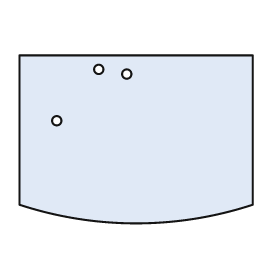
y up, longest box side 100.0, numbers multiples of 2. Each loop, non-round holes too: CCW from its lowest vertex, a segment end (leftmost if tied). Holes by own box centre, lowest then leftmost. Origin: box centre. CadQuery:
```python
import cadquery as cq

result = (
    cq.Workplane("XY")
    .moveTo(-50.0, -28.0)
    .threePointArc((0.0, -36.0), (50.0, -28.0))
    .lineTo(50.0, 36.0)
    .lineTo(-50.0, 36.0)
    .close()
    .moveTo(-34.0, 8.0)
    .circle(2.0)
    .moveTo(-4.0, 28.0)
    .circle(2.0)
    .moveTo(-16.0, 30.0)
    .circle(2.0)
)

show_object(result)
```